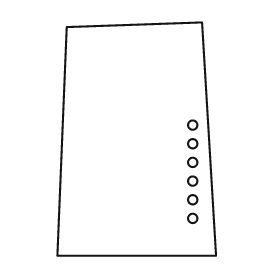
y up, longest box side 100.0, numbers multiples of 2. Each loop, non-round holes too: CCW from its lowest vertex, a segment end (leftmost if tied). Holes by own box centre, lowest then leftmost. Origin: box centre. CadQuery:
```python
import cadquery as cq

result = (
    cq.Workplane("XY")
    .moveTo(-34.0, -50.0)
    .lineTo(34.0, -50.0)
    .lineTo(28.0, 50.0)
    .lineTo(-30.0, 48.0)
    .close()
    .moveTo(24.0, -34.0)
    .circle(2.0)
    .moveTo(24.0, -26.0)
    .circle(2.0)
    .moveTo(24.0, -18.0)
    .circle(2.0)
    .moveTo(24.0, -10.0)
    .circle(2.0)
    .moveTo(24.0, -2.0)
    .circle(2.0)
    .moveTo(24.0, 6.0)
    .circle(2.0)
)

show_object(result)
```